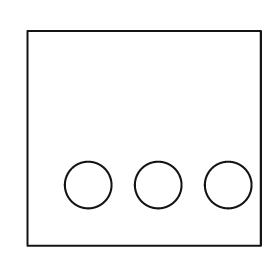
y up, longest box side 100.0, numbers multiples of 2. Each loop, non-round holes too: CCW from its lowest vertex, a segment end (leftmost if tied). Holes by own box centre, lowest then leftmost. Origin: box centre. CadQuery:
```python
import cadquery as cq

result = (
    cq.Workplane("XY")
    .moveTo(-50.0, -46.0)
    .lineTo(50.0, -46.0)
    .lineTo(50.0, 46.0)
    .lineTo(-50.0, 46.0)
    .close()
    .moveTo(-24.0, -20.0)
    .circle(10.0)
    .moveTo(6.0, -20.0)
    .circle(10.0)
    .moveTo(36.0, -20.0)
    .circle(10.0)
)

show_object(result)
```